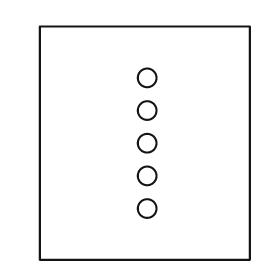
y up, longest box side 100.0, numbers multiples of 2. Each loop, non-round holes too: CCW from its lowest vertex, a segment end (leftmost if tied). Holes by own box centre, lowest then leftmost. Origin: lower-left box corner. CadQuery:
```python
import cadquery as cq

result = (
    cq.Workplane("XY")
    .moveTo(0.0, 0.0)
    .lineTo(90.0, 0.0)
    .lineTo(90.0, 100.0)
    .lineTo(0.0, 100.0)
    .close()
    .moveTo(46.0, 22.0)
    .circle(4.0)
    .moveTo(46.0, 36.0)
    .circle(4.0)
    .moveTo(46.0, 50.0)
    .circle(4.0)
    .moveTo(46.0, 64.0)
    .circle(4.0)
    .moveTo(46.0, 78.0)
    .circle(4.0)
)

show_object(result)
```